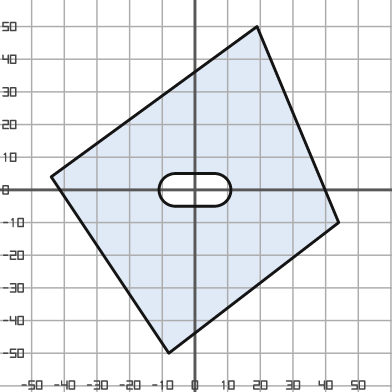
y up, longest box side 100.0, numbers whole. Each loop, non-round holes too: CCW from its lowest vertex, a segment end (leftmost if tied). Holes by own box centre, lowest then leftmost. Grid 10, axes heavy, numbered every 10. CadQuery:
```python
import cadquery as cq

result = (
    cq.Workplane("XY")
    .moveTo(-8.0, -50.0)
    .lineTo(44.0, -10.0)
    .lineTo(19.0, 50.0)
    .lineTo(-44.0, 4.0)
    .close()
    .moveTo(-6.0, -5.0)
    .lineTo(6.0, -5.0)
    .threePointArc((11.0, 0.0), (6.0, 5.0))
    .lineTo(-6.0, 5.0)
    .threePointArc((-11.0, 0.0), (-6.0, -5.0))
    .close()
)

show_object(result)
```